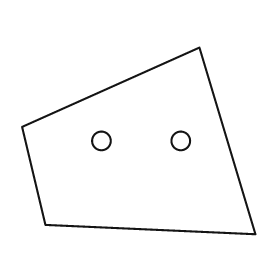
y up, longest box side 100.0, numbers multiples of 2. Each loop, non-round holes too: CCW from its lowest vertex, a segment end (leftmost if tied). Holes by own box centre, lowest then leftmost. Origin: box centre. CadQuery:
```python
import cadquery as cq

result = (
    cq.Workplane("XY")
    .moveTo(50.0, -40.0)
    .lineTo(26.0, 40.0)
    .lineTo(-50.0, 6.0)
    .lineTo(-40.0, -36.0)
    .close()
    .moveTo(-16.0, 0.0)
    .circle(4.0)
    .moveTo(18.0, 0.0)
    .circle(4.0)
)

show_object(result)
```